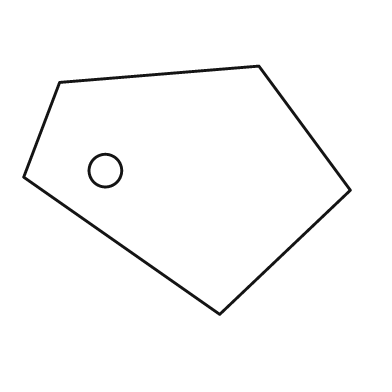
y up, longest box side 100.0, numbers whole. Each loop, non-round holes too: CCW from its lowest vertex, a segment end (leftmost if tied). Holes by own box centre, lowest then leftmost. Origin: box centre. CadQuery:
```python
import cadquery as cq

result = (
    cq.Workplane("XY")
    .moveTo(10.0, -38.0)
    .lineTo(50.0, 0.0)
    .lineTo(22.0, 38.0)
    .lineTo(-39.0, 33.0)
    .lineTo(-50.0, 4.0)
    .close()
    .moveTo(-25.0, 6.0)
    .circle(5.0)
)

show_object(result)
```